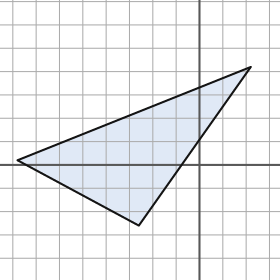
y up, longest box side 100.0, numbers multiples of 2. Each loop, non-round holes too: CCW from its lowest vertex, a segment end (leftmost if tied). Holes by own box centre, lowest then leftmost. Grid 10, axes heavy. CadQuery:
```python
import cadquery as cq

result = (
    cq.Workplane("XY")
    .moveTo(-26.0, -26.0)
    .lineTo(22.0, 42.0)
    .lineTo(-78.0, 2.0)
    .close()
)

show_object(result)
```